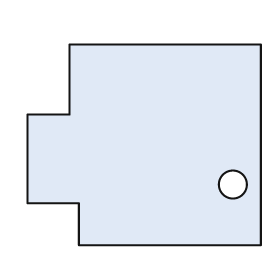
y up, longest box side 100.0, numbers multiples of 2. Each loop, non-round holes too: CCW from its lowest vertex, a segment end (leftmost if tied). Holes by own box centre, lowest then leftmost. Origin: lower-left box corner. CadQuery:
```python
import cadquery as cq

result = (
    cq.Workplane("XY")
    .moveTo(22.0, 0.0)
    .lineTo(100.0, 0.0)
    .lineTo(100.0, 86.0)
    .lineTo(18.0, 86.0)
    .lineTo(18.0, 56.0)
    .lineTo(0.0, 56.0)
    .lineTo(0.0, 18.0)
    .lineTo(22.0, 18.0)
    .close()
    .moveTo(88.0, 26.0)
    .circle(6.0)
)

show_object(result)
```